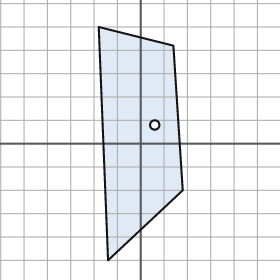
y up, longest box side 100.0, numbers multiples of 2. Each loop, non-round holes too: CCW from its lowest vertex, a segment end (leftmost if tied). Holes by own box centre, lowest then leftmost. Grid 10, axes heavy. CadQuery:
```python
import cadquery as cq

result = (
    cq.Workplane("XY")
    .moveTo(-14.0, -50.0)
    .lineTo(18.0, -20.0)
    .lineTo(14.0, 42.0)
    .lineTo(-18.0, 50.0)
    .close()
    .moveTo(6.0, 8.0)
    .circle(2.0)
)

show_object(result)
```